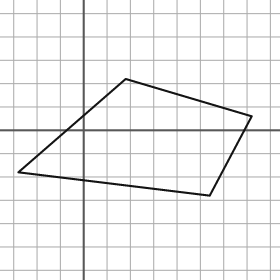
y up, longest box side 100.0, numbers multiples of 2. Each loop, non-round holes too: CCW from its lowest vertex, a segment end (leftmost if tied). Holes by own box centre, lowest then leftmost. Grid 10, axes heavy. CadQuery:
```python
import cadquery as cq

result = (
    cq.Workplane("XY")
    .moveTo(54.0, -28.0)
    .lineTo(72.0, 6.0)
    .lineTo(18.0, 22.0)
    .lineTo(-28.0, -18.0)
    .close()
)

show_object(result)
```